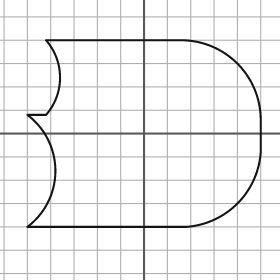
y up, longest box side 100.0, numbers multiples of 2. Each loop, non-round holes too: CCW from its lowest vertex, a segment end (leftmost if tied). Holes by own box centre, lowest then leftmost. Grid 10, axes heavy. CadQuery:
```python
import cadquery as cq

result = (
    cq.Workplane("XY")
    .moveTo(-50.0, -40.0)
    .lineTo(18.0, -40.0)
    .threePointArc((40.0, -30.0), (50.0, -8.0))
    .lineTo(50.0, 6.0)
    .threePointArc((40.0, 30.0), (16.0, 40.0))
    .lineTo(-42.0, 40.0)
    .threePointArc((-36.0, 24.0), (-42.0, 8.0))
    .lineTo(-50.0, 8.0)
    .threePointArc((-38.0, -16.0), (-50.0, -40.0))
    .close()
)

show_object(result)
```